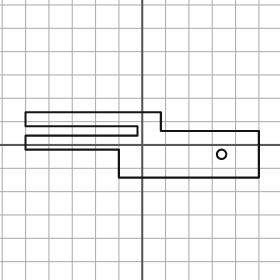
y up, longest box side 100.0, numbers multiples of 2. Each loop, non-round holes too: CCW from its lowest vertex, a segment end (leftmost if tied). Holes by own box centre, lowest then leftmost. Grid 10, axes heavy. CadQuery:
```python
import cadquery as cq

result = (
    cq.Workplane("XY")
    .moveTo(-10.0, -14.0)
    .lineTo(50.0, -14.0)
    .lineTo(50.0, 6.0)
    .lineTo(8.0, 6.0)
    .lineTo(8.0, 14.0)
    .lineTo(-50.0, 14.0)
    .lineTo(-50.0, 8.0)
    .lineTo(-2.0, 8.0)
    .lineTo(-2.0, 4.0)
    .lineTo(-50.0, 4.0)
    .lineTo(-50.0, -2.0)
    .lineTo(-10.0, -2.0)
    .close()
    .moveTo(34.0, -4.0)
    .circle(2.0)
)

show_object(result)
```